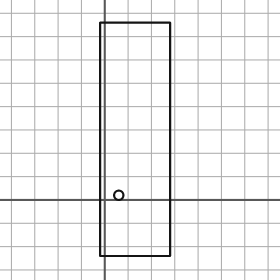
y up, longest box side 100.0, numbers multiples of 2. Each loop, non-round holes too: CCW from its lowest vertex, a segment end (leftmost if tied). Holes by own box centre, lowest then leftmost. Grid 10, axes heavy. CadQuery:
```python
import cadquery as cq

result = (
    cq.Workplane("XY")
    .moveTo(-2.0, -24.0)
    .lineTo(28.0, -24.0)
    .lineTo(28.0, 76.0)
    .lineTo(-2.0, 76.0)
    .close()
    .moveTo(6.0, 2.0)
    .circle(2.0)
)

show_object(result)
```